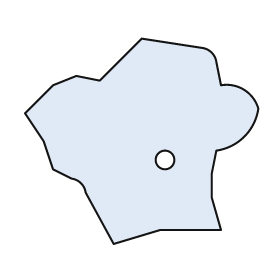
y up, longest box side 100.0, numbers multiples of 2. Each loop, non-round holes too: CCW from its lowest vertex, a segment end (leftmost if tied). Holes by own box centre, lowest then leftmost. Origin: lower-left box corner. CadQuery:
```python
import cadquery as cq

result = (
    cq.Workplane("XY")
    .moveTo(38.0, 0.0)
    .lineTo(58.0, 6.0)
    .lineTo(84.0, 6.0)
    .lineTo(80.0, 20.0)
    .lineTo(80.0, 30.0)
    .lineTo(82.0, 40.0)
    .threePointArc((94.0, 46.0), (100.0, 58.0))
    .threePointArc((94.0, 66.0), (84.0, 68.0))
    .lineTo(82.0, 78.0)
    .threePointArc((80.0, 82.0), (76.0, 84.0))
    .lineTo(50.0, 88.0)
    .lineTo(32.0, 70.0)
    .lineTo(22.0, 72.0)
    .lineTo(12.0, 68.0)
    .lineTo(0.0, 56.0)
    .lineTo(8.0, 44.0)
    .lineTo(12.0, 32.0)
    .lineTo(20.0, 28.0)
    .threePointArc((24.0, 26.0), (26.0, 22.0))
    .close()
    .moveTo(60.0, 36.0)
    .circle(4.0)
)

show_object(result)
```